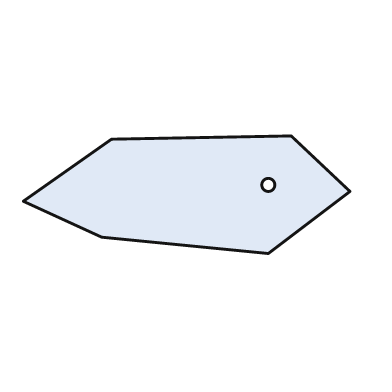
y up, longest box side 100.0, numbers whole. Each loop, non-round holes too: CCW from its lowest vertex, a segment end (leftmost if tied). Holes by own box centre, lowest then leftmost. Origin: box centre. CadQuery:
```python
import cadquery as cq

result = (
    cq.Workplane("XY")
    .moveTo(25.0, -18.0)
    .lineTo(50.0, 1.0)
    .lineTo(32.0, 18.0)
    .lineTo(-23.0, 17.0)
    .lineTo(-50.0, -2.0)
    .lineTo(-26.0, -13.0)
    .close()
    .moveTo(25.0, 3.0)
    .circle(2.0)
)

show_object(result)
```